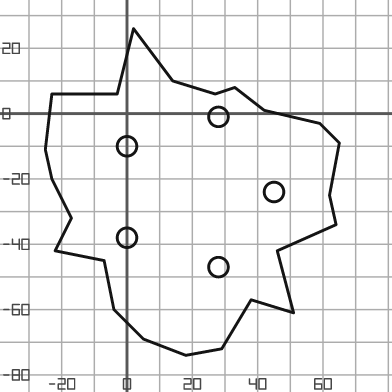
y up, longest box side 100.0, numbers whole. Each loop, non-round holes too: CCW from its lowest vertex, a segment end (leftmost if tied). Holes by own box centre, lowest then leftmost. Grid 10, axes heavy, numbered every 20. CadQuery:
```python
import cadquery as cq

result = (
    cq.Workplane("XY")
    .moveTo(18.0, -74.0)
    .lineTo(29.0, -72.0)
    .lineTo(38.0, -57.0)
    .lineTo(51.0, -61.0)
    .lineTo(46.0, -42.0)
    .lineTo(64.0, -34.0)
    .lineTo(62.0, -25.0)
    .lineTo(65.0, -9.0)
    .lineTo(59.0, -3.0)
    .lineTo(42.0, 1.0)
    .lineTo(33.0, 8.0)
    .lineTo(27.0, 6.0)
    .lineTo(14.0, 10.0)
    .lineTo(2.0, 26.0)
    .lineTo(-3.0, 6.0)
    .lineTo(-23.0, 6.0)
    .lineTo(-25.0, -11.0)
    .lineTo(-23.0, -20.0)
    .lineTo(-17.0, -32.0)
    .lineTo(-22.0, -42.0)
    .lineTo(-7.0, -45.0)
    .lineTo(-4.0, -60.0)
    .lineTo(5.0, -69.0)
    .close()
    .moveTo(28.0, -47.0)
    .circle(3.0)
    .moveTo(0.0, -38.0)
    .circle(3.0)
    .moveTo(45.0, -24.0)
    .circle(3.0)
    .moveTo(0.0, -10.0)
    .circle(3.0)
    .moveTo(28.0, -1.0)
    .circle(3.0)
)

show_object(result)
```